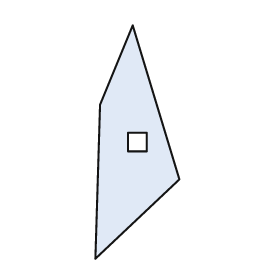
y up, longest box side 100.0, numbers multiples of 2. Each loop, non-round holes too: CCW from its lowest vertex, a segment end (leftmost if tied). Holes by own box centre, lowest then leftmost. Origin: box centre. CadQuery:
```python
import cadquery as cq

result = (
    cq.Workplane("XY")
    .moveTo(-18.0, -50.0)
    .lineTo(18.0, -16.0)
    .lineTo(-2.0, 50.0)
    .lineTo(-16.0, 16.0)
    .close()
    .moveTo(-4.0, -4.0)
    .lineTo(4.0, -4.0)
    .lineTo(4.0, 4.0)
    .lineTo(-4.0, 4.0)
    .close()
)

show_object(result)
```